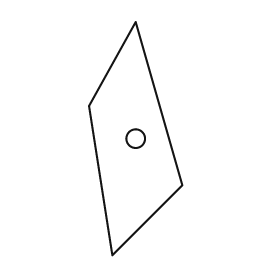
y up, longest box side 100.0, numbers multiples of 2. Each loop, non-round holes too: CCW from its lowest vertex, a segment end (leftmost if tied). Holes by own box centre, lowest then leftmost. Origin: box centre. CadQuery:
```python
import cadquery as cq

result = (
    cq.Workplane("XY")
    .moveTo(-10.0, -50.0)
    .lineTo(20.0, -20.0)
    .lineTo(0.0, 50.0)
    .lineTo(-20.0, 14.0)
    .close()
    .moveTo(0.0, 0.0)
    .circle(4.0)
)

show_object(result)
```